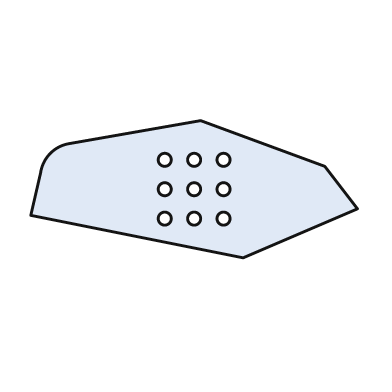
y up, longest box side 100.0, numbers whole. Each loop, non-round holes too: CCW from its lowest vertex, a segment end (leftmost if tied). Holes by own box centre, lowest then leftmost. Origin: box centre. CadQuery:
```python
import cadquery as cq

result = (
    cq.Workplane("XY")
    .moveTo(15.0, -21.0)
    .lineTo(50.0, -6.0)
    .lineTo(40.0, 7.0)
    .lineTo(2.0, 21.0)
    .lineTo(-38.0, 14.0)
    .threePointArc((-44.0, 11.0), (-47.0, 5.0))
    .lineTo(-50.0, -8.0)
    .close()
    .moveTo(-9.0, -9.0)
    .circle(2.0)
    .moveTo(0.0, -9.0)
    .circle(2.0)
    .moveTo(9.0, -9.0)
    .circle(2.0)
    .moveTo(-9.0, 0.0)
    .circle(2.0)
    .moveTo(0.0, 0.0)
    .circle(2.0)
    .moveTo(9.0, 0.0)
    .circle(2.0)
    .moveTo(-9.0, 9.0)
    .circle(2.0)
    .moveTo(0.0, 9.0)
    .circle(2.0)
    .moveTo(9.0, 9.0)
    .circle(2.0)
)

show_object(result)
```